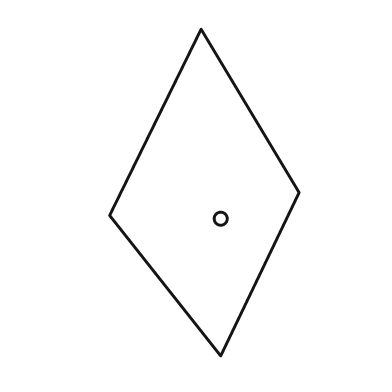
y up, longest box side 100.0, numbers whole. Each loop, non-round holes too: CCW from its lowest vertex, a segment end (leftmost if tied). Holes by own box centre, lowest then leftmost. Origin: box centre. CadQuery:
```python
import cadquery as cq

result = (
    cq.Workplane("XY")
    .moveTo(5.0, -50.0)
    .lineTo(29.0, 0.0)
    .lineTo(-1.0, 50.0)
    .lineTo(-29.0, -7.0)
    .close()
    .moveTo(5.0, -8.0)
    .circle(2.0)
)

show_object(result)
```